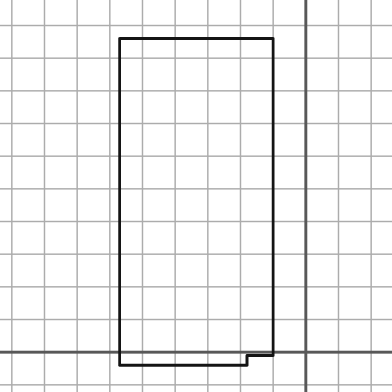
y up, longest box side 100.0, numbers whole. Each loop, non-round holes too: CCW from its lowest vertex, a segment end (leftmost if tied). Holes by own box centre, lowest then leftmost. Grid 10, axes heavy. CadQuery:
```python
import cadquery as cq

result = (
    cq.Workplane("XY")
    .moveTo(-57.0, -4.0)
    .lineTo(-18.0, -4.0)
    .lineTo(-18.0, -1.0)
    .lineTo(-10.0, -1.0)
    .lineTo(-10.0, 96.0)
    .lineTo(-57.0, 96.0)
    .close()
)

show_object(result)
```